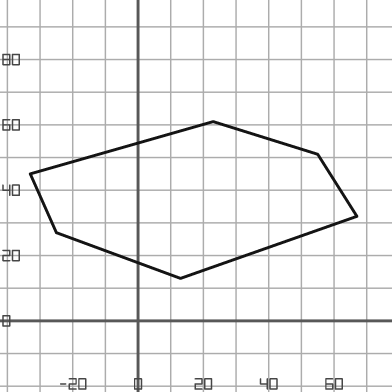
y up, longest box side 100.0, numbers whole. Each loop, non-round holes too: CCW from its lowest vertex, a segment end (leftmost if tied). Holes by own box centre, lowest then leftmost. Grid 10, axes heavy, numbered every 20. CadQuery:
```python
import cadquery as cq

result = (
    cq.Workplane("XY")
    .moveTo(13.0, 13.0)
    .lineTo(67.0, 32.0)
    .lineTo(55.0, 51.0)
    .lineTo(23.0, 61.0)
    .lineTo(-33.0, 45.0)
    .lineTo(-25.0, 27.0)
    .close()
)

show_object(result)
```